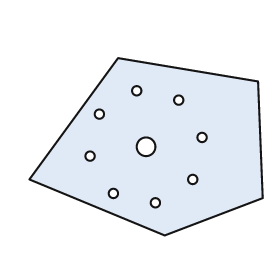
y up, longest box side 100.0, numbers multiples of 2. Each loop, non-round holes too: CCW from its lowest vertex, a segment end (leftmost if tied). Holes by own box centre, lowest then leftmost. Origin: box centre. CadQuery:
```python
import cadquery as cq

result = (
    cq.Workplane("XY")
    .moveTo(8.0, -38.0)
    .lineTo(50.0, -22.0)
    .lineTo(48.0, 28.0)
    .lineTo(-12.0, 38.0)
    .lineTo(-50.0, -14.0)
    .close()
    .moveTo(4.0, -24.0)
    .circle(2.0)
    .moveTo(-14.0, -20.0)
    .circle(2.0)
    .moveTo(20.0, -14.0)
    .circle(2.0)
    .moveTo(-24.0, -4.0)
    .circle(2.0)
    .moveTo(0.0, 0.0)
    .circle(4.0)
    .moveTo(24.0, 4.0)
    .circle(2.0)
    .moveTo(-20.0, 14.0)
    .circle(2.0)
    .moveTo(14.0, 20.0)
    .circle(2.0)
    .moveTo(-4.0, 24.0)
    .circle(2.0)
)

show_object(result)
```